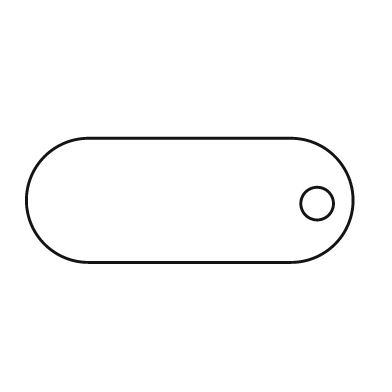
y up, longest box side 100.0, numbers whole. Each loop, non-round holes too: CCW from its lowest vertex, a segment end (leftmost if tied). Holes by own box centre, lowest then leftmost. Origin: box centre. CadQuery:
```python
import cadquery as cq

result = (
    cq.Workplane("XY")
    .moveTo(-31.0, -19.0)
    .lineTo(31.0, -19.0)
    .threePointArc((50.0, 0.0), (31.0, 19.0))
    .lineTo(-31.0, 19.0)
    .threePointArc((-50.0, 0.0), (-31.0, -19.0))
    .close()
    .moveTo(39.0, -1.0)
    .circle(5.0)
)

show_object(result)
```